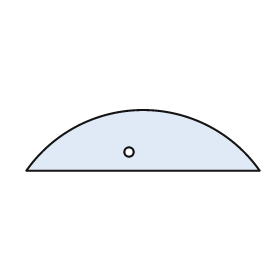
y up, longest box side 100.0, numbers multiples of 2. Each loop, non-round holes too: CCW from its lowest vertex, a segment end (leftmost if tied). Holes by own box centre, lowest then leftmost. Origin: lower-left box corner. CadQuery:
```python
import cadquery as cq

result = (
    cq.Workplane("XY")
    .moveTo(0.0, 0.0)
    .lineTo(100.0, 0.0)
    .threePointArc((50.0, 26.0), (0.0, 0.0))
    .close()
    .moveTo(44.0, 8.0)
    .circle(2.0)
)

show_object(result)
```